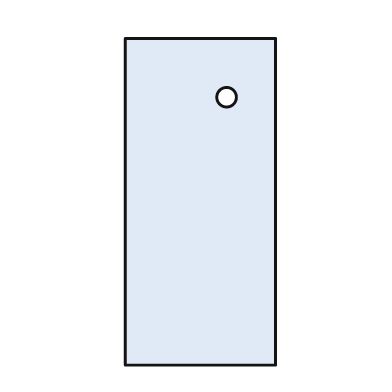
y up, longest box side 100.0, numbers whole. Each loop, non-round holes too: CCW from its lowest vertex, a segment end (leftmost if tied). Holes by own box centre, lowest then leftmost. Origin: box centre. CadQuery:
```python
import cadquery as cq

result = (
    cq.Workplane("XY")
    .moveTo(-23.0, -50.0)
    .lineTo(23.0, -50.0)
    .lineTo(23.0, 50.0)
    .lineTo(-23.0, 50.0)
    .close()
    .moveTo(8.0, 32.0)
    .circle(3.0)
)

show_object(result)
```